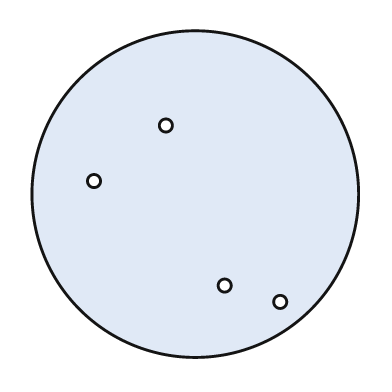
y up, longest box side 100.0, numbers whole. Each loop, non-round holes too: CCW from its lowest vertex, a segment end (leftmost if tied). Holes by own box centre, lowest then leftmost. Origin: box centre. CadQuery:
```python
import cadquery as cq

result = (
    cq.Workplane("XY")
    .moveTo(0.0, 0.0)
    .circle(50.0)
    .moveTo(26.0, -33.0)
    .circle(2.0)
    .moveTo(9.0, -28.0)
    .circle(2.0)
    .moveTo(-31.0, 4.0)
    .circle(2.0)
    .moveTo(-9.0, 21.0)
    .circle(2.0)
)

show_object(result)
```